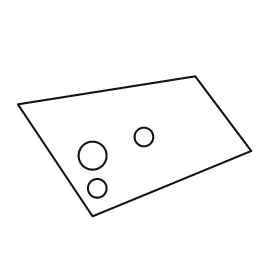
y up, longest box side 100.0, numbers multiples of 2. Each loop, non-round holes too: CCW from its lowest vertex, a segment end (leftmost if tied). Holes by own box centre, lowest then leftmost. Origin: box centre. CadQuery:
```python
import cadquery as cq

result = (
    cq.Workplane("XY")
    .moveTo(-18.0, -30.0)
    .lineTo(50.0, -2.0)
    .lineTo(26.0, 30.0)
    .lineTo(-50.0, 18.0)
    .close()
    .moveTo(-16.0, -18.0)
    .circle(4.0)
    .moveTo(-18.0, -4.0)
    .circle(6.0)
    .moveTo(4.0, 4.0)
    .circle(4.0)
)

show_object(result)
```